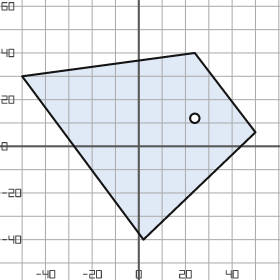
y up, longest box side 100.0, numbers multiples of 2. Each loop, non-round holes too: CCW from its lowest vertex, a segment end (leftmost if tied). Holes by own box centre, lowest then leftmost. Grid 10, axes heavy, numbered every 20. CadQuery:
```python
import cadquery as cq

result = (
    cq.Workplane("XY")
    .moveTo(2.0, -40.0)
    .lineTo(50.0, 6.0)
    .lineTo(24.0, 40.0)
    .lineTo(-50.0, 30.0)
    .close()
    .moveTo(24.0, 12.0)
    .circle(2.0)
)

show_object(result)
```